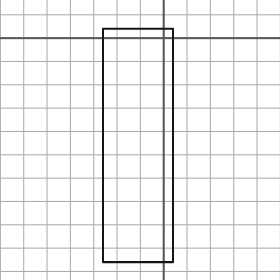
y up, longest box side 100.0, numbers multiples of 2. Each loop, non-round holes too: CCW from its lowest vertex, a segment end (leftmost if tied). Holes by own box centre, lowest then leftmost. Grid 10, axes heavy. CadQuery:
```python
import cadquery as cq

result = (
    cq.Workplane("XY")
    .moveTo(-26.0, -96.0)
    .lineTo(4.0, -96.0)
    .lineTo(4.0, 4.0)
    .lineTo(-26.0, 4.0)
    .close()
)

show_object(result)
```